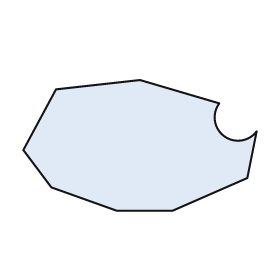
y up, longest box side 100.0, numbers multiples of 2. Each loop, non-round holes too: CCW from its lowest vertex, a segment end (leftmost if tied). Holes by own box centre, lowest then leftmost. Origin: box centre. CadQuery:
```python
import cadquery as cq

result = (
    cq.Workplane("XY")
    .moveTo(-10.0, -28.0)
    .lineTo(14.0, -28.0)
    .lineTo(46.0, -14.0)
    .lineTo(50.0, 6.0)
    .threePointArc((36.0, 4.0), (34.0, 18.0))
    .lineTo(0.0, 28.0)
    .lineTo(-36.0, 24.0)
    .lineTo(-50.0, -2.0)
    .lineTo(-38.0, -18.0)
    .close()
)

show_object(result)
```